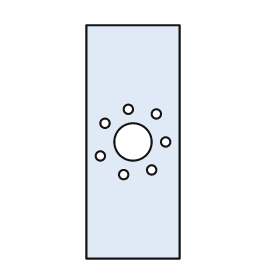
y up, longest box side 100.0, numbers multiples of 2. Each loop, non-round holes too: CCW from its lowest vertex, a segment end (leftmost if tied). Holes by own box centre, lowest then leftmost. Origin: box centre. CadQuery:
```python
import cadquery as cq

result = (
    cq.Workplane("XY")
    .moveTo(-20.0, -50.0)
    .lineTo(20.0, -50.0)
    .lineTo(20.0, 50.0)
    .lineTo(-20.0, 50.0)
    .close()
    .moveTo(-4.0, -14.0)
    .circle(2.0)
    .moveTo(8.0, -12.0)
    .circle(2.0)
    .moveTo(-14.0, -6.0)
    .circle(2.0)
    .moveTo(0.0, 0.0)
    .circle(8.0)
    .moveTo(14.0, 0.0)
    .circle(2.0)
    .moveTo(-12.0, 8.0)
    .circle(2.0)
    .moveTo(10.0, 12.0)
    .circle(2.0)
    .moveTo(-2.0, 14.0)
    .circle(2.0)
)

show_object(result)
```